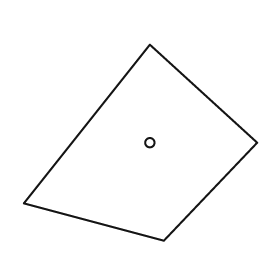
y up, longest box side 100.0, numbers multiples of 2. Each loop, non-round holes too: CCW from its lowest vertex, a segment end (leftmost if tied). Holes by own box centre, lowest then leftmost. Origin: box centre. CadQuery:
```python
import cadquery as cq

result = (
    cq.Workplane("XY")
    .moveTo(10.0, -42.0)
    .lineTo(50.0, 0.0)
    .lineTo(4.0, 42.0)
    .lineTo(-50.0, -26.0)
    .close()
    .moveTo(4.0, 0.0)
    .circle(2.0)
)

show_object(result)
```